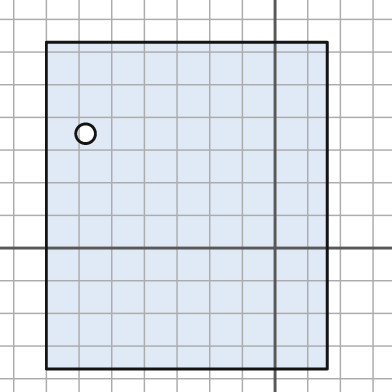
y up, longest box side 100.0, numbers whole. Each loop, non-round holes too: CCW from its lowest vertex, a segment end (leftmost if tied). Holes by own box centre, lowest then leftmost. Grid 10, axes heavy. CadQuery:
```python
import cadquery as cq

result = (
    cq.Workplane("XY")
    .moveTo(-70.0, -37.0)
    .lineTo(16.0, -37.0)
    .lineTo(16.0, 63.0)
    .lineTo(-70.0, 63.0)
    .close()
    .moveTo(-58.0, 35.0)
    .circle(3.0)
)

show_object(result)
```